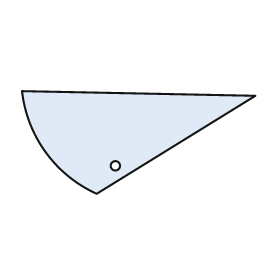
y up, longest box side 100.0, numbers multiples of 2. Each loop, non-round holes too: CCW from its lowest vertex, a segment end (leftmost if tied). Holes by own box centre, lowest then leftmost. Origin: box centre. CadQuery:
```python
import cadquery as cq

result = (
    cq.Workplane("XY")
    .moveTo(-18.0, -22.0)
    .lineTo(50.0, 20.0)
    .lineTo(-50.0, 22.0)
    .threePointArc((-40.0, -4.0), (-18.0, -22.0))
    .close()
    .moveTo(-10.0, -10.0)
    .circle(2.0)
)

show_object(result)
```